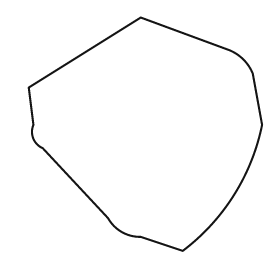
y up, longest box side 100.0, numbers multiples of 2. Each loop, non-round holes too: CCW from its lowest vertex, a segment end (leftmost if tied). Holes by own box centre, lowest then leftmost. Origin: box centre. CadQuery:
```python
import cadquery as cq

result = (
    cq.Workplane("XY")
    .moveTo(16.0, -50.0)
    .threePointArc((38.0, -26.0), (50.0, 4.0))
    .lineTo(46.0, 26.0)
    .threePointArc((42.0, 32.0), (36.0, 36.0))
    .lineTo(-2.0, 50.0)
    .lineTo(-50.0, 20.0)
    .lineTo(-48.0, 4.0)
    .threePointArc((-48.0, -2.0), (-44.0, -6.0))
    .lineTo(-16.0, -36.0)
    .threePointArc((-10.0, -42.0), (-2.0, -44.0))
    .close()
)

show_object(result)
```